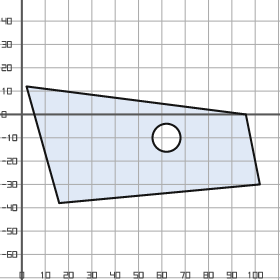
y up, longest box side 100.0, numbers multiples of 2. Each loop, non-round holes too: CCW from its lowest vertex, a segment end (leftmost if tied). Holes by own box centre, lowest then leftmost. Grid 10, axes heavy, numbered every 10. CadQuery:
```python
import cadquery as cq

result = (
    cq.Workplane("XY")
    .moveTo(16.0, -38.0)
    .lineTo(102.0, -30.0)
    .lineTo(96.0, 0.0)
    .lineTo(2.0, 12.0)
    .close()
    .moveTo(62.0, -10.0)
    .circle(6.0)
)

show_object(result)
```